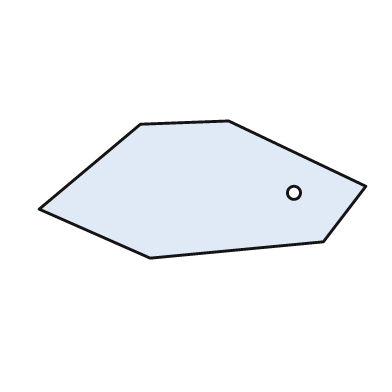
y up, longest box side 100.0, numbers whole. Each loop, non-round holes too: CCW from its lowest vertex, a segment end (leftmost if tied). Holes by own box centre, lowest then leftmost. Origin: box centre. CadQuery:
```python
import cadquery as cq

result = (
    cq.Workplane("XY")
    .moveTo(-16.0, -21.0)
    .lineTo(37.0, -16.0)
    .lineTo(50.0, 1.0)
    .lineTo(8.0, 21.0)
    .lineTo(-19.0, 20.0)
    .lineTo(-50.0, -6.0)
    .close()
    .moveTo(28.0, -1.0)
    .circle(2.0)
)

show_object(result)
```